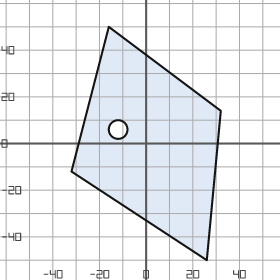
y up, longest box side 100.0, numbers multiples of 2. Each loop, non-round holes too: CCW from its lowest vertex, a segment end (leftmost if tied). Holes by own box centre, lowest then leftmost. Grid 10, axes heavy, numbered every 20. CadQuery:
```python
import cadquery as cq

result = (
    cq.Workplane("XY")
    .moveTo(26.0, -50.0)
    .lineTo(32.0, 14.0)
    .lineTo(-16.0, 50.0)
    .lineTo(-32.0, -12.0)
    .close()
    .moveTo(-12.0, 6.0)
    .circle(4.0)
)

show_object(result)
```